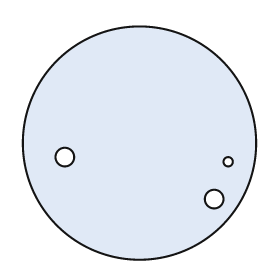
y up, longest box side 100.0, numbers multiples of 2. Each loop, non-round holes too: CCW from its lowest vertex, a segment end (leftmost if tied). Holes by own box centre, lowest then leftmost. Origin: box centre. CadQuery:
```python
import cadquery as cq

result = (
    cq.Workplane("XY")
    .moveTo(0.0, 0.0)
    .circle(50.0)
    .moveTo(32.0, -24.0)
    .circle(4.0)
    .moveTo(38.0, -8.0)
    .circle(2.0)
    .moveTo(-32.0, -6.0)
    .circle(4.0)
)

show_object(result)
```